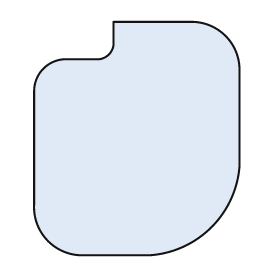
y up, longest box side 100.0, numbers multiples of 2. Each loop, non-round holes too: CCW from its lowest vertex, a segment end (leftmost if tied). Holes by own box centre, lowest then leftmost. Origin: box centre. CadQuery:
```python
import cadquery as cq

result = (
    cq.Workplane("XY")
    .moveTo(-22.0, -50.0)
    .lineTo(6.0, -50.0)
    .threePointArc((32.0, -38.0), (44.0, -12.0))
    .lineTo(44.0, 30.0)
    .threePointArc((38.0, 44.0), (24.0, 50.0))
    .lineTo(-10.0, 50.0)
    .lineTo(-10.0, 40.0)
    .threePointArc((-12.0, 36.0), (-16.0, 34.0))
    .lineTo(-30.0, 34.0)
    .threePointArc((-40.0, 30.0), (-44.0, 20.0))
    .lineTo(-44.0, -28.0)
    .threePointArc((-38.0, -44.0), (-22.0, -50.0))
    .close()
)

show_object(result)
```